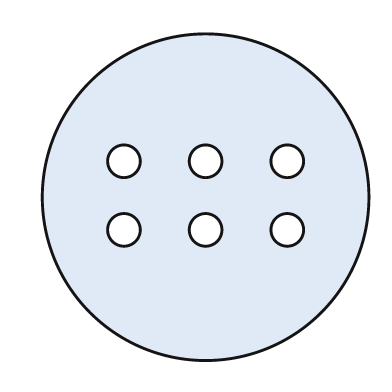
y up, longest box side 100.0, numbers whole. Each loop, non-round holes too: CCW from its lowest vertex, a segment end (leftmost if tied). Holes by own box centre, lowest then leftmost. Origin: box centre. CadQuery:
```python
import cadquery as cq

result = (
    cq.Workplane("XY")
    .moveTo(0.0, 0.0)
    .circle(50.0)
    .moveTo(-25.0, -10.0)
    .circle(5.0)
    .moveTo(0.0, -10.0)
    .circle(5.0)
    .moveTo(25.0, -10.0)
    .circle(5.0)
    .moveTo(-25.0, 11.0)
    .circle(5.0)
    .moveTo(0.0, 11.0)
    .circle(5.0)
    .moveTo(25.0, 11.0)
    .circle(5.0)
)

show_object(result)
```